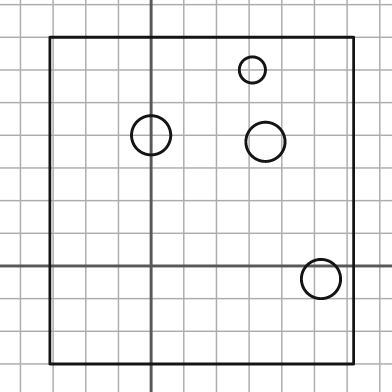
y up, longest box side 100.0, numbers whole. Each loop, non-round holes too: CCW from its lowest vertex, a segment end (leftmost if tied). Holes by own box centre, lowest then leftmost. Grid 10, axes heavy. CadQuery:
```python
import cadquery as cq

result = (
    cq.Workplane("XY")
    .moveTo(-31.0, -30.0)
    .lineTo(62.0, -30.0)
    .lineTo(62.0, 70.0)
    .lineTo(-31.0, 70.0)
    .close()
    .moveTo(52.0, -4.0)
    .circle(6.0)
    .moveTo(35.0, 38.0)
    .circle(6.0)
    .moveTo(0.0, 40.0)
    .circle(6.0)
    .moveTo(31.0, 60.0)
    .circle(4.0)
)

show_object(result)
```